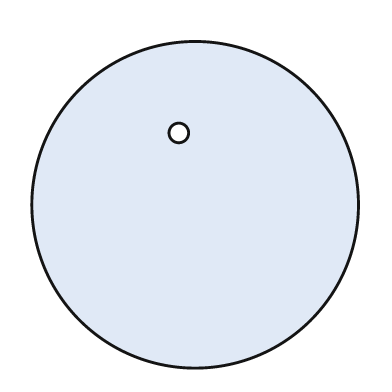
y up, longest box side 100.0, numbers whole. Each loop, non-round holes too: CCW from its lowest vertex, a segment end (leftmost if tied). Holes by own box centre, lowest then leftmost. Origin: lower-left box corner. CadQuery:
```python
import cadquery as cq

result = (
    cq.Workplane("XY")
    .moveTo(50.0, 50.0)
    .circle(50.0)
    .moveTo(45.0, 72.0)
    .circle(3.0)
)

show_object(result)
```